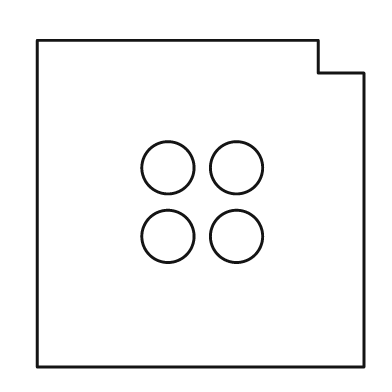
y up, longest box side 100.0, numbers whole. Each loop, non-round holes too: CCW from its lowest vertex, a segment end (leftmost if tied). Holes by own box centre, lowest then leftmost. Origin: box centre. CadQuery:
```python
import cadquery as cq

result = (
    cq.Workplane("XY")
    .moveTo(-50.0, -50.0)
    .lineTo(50.0, -50.0)
    .lineTo(50.0, 40.0)
    .lineTo(36.0, 40.0)
    .lineTo(36.0, 50.0)
    .lineTo(-50.0, 50.0)
    .close()
    .moveTo(-10.0, -10.0)
    .circle(8.0)
    .moveTo(11.0, -10.0)
    .circle(8.0)
    .moveTo(-10.0, 11.0)
    .circle(8.0)
    .moveTo(11.0, 11.0)
    .circle(8.0)
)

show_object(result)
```